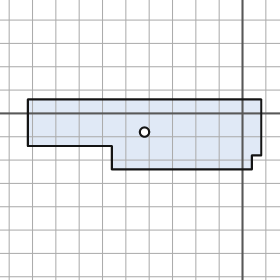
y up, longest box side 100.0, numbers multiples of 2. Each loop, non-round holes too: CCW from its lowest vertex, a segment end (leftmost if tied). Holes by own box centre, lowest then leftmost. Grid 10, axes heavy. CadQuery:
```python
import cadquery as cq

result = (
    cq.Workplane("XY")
    .moveTo(-56.0, -24.0)
    .lineTo(4.0, -24.0)
    .lineTo(4.0, -18.0)
    .lineTo(8.0, -18.0)
    .lineTo(8.0, 6.0)
    .lineTo(-92.0, 6.0)
    .lineTo(-92.0, -14.0)
    .lineTo(-56.0, -14.0)
    .close()
    .moveTo(-42.0, -8.0)
    .circle(2.0)
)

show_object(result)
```